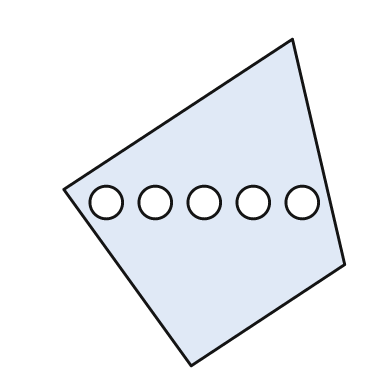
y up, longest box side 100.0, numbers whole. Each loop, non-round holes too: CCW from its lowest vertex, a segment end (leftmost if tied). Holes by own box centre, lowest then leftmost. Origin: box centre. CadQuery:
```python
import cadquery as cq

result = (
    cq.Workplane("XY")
    .moveTo(-4.0, -50.0)
    .lineTo(43.0, -19.0)
    .lineTo(27.0, 50.0)
    .lineTo(-43.0, 4.0)
    .close()
    .moveTo(-30.0, 0.0)
    .circle(5.0)
    .moveTo(-15.0, 0.0)
    .circle(5.0)
    .moveTo(0.0, 0.0)
    .circle(5.0)
    .moveTo(15.0, 0.0)
    .circle(5.0)
    .moveTo(30.0, 0.0)
    .circle(5.0)
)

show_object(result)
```